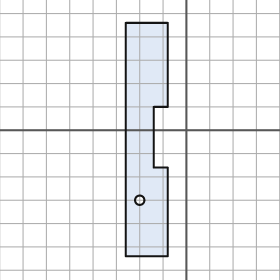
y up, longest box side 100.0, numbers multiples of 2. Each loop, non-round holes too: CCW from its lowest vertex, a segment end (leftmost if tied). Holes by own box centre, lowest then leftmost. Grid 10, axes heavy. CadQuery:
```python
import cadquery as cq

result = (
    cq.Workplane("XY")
    .moveTo(-26.0, -54.0)
    .lineTo(-8.0, -54.0)
    .lineTo(-8.0, -16.0)
    .lineTo(-14.0, -16.0)
    .lineTo(-14.0, 10.0)
    .lineTo(-8.0, 10.0)
    .lineTo(-8.0, 46.0)
    .lineTo(-26.0, 46.0)
    .close()
    .moveTo(-20.0, -30.0)
    .circle(2.0)
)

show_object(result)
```